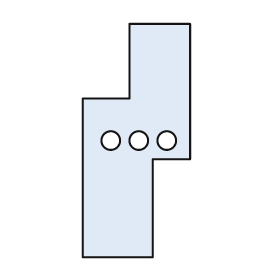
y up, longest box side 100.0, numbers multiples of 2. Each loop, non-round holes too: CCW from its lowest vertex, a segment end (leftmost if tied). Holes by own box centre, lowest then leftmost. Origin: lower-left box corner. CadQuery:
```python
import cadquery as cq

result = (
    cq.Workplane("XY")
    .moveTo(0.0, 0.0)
    .lineTo(30.0, 0.0)
    .lineTo(30.0, 42.0)
    .lineTo(46.0, 42.0)
    .lineTo(46.0, 100.0)
    .lineTo(20.0, 100.0)
    .lineTo(20.0, 68.0)
    .lineTo(0.0, 68.0)
    .close()
    .moveTo(12.0, 50.0)
    .circle(4.0)
    .moveTo(24.0, 50.0)
    .circle(4.0)
    .moveTo(36.0, 50.0)
    .circle(4.0)
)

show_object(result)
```